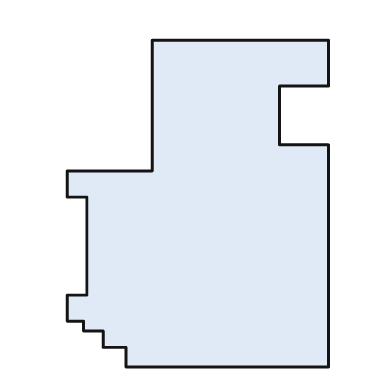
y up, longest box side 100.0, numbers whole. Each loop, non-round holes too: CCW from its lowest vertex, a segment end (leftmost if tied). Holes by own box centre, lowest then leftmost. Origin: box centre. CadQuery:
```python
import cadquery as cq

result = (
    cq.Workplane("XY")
    .moveTo(-22.0, -50.0)
    .lineTo(40.0, -50.0)
    .lineTo(40.0, 18.0)
    .lineTo(25.0, 18.0)
    .lineTo(25.0, 36.0)
    .lineTo(40.0, 36.0)
    .lineTo(40.0, 50.0)
    .lineTo(-14.0, 50.0)
    .lineTo(-14.0, 10.0)
    .lineTo(-40.0, 10.0)
    .lineTo(-40.0, 2.0)
    .lineTo(-34.0, 2.0)
    .lineTo(-34.0, -28.0)
    .lineTo(-40.0, -28.0)
    .lineTo(-40.0, -36.0)
    .lineTo(-35.0, -36.0)
    .lineTo(-35.0, -39.0)
    .lineTo(-29.0, -39.0)
    .lineTo(-29.0, -44.0)
    .lineTo(-22.0, -44.0)
    .close()
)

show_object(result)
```